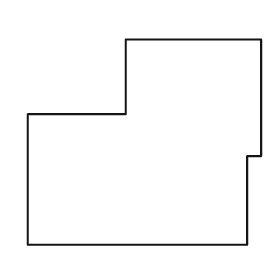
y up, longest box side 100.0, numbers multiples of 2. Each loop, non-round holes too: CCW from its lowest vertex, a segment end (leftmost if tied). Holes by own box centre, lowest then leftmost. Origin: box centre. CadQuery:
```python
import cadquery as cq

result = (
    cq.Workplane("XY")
    .moveTo(-50.0, -44.0)
    .lineTo(44.0, -44.0)
    .lineTo(44.0, -6.0)
    .lineTo(50.0, -6.0)
    .lineTo(50.0, 44.0)
    .lineTo(-8.0, 44.0)
    .lineTo(-8.0, 12.0)
    .lineTo(-50.0, 12.0)
    .close()
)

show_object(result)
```